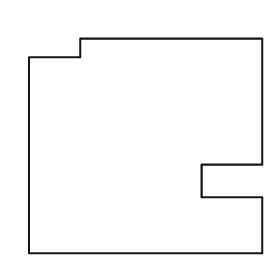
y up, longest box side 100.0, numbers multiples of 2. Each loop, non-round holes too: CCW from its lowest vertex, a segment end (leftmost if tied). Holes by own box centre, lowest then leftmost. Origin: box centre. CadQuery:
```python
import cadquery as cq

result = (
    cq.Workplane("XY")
    .moveTo(-50.0, -46.0)
    .lineTo(50.0, -46.0)
    .lineTo(50.0, -22.0)
    .lineTo(24.0, -22.0)
    .lineTo(24.0, -8.0)
    .lineTo(50.0, -8.0)
    .lineTo(50.0, 46.0)
    .lineTo(-28.0, 46.0)
    .lineTo(-28.0, 38.0)
    .lineTo(-50.0, 38.0)
    .close()
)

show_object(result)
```